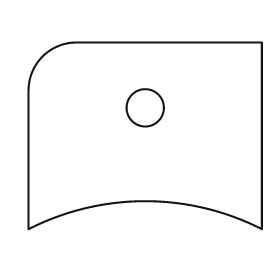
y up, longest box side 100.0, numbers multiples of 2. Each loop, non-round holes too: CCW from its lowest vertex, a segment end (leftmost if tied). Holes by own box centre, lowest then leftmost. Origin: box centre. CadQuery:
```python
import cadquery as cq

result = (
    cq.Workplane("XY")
    .moveTo(-50.0, -40.0)
    .threePointArc((0.0, -28.0), (50.0, -40.0))
    .lineTo(50.0, 40.0)
    .lineTo(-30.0, 40.0)
    .threePointArc((-44.0, 34.0), (-50.0, 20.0))
    .close()
    .moveTo(0.0, 12.0)
    .circle(8.0)
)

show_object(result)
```